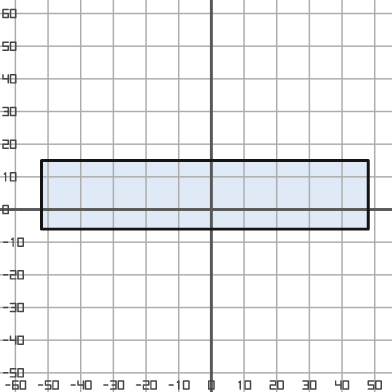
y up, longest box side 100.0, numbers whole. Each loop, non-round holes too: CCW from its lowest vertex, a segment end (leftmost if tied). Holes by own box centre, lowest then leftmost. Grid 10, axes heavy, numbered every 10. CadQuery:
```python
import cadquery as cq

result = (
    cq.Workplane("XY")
    .moveTo(-52.0, -6.0)
    .lineTo(48.0, -6.0)
    .lineTo(48.0, 15.0)
    .lineTo(-52.0, 15.0)
    .close()
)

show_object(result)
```